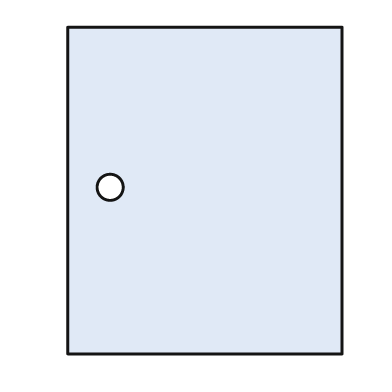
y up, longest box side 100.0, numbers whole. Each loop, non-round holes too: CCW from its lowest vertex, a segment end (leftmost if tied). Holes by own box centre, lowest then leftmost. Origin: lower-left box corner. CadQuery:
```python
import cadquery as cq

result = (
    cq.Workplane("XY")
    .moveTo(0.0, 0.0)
    .lineTo(84.0, 0.0)
    .lineTo(84.0, 100.0)
    .lineTo(0.0, 100.0)
    .close()
    .moveTo(13.0, 51.0)
    .circle(4.0)
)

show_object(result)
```